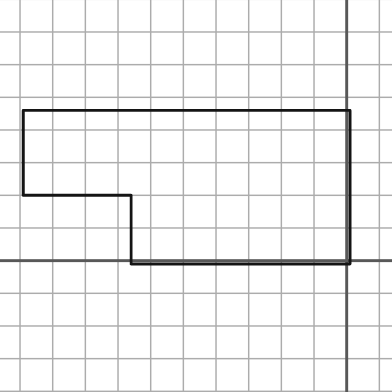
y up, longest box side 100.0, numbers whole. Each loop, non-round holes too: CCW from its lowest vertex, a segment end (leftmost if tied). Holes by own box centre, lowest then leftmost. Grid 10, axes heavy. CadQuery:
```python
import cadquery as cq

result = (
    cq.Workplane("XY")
    .moveTo(-66.0, -1.0)
    .lineTo(1.0, -1.0)
    .lineTo(1.0, 46.0)
    .lineTo(-99.0, 46.0)
    .lineTo(-99.0, 20.0)
    .lineTo(-66.0, 20.0)
    .close()
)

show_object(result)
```